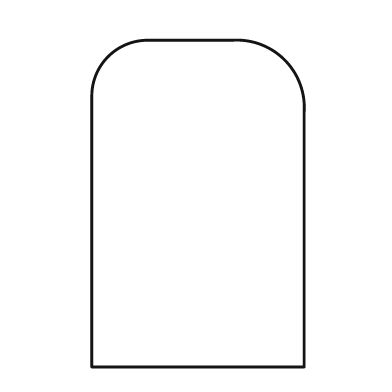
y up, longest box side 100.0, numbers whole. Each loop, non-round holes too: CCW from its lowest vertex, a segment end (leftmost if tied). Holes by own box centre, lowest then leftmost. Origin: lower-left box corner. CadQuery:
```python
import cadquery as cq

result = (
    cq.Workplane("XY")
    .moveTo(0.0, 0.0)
    .lineTo(65.0, 0.0)
    .lineTo(65.0, 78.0)
    .threePointArc((59.0, 94.0), (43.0, 100.0))
    .lineTo(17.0, 100.0)
    .threePointArc((5.0, 95.0), (0.0, 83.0))
    .close()
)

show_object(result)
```